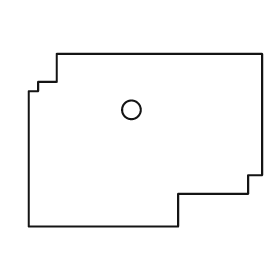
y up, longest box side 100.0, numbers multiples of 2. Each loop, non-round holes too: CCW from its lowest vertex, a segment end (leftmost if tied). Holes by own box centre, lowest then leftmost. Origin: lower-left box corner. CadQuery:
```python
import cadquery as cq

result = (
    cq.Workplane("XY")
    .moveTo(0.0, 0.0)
    .lineTo(64.0, 0.0)
    .lineTo(64.0, 14.0)
    .lineTo(94.0, 14.0)
    .lineTo(94.0, 22.0)
    .lineTo(100.0, 22.0)
    .lineTo(100.0, 74.0)
    .lineTo(12.0, 74.0)
    .lineTo(12.0, 62.0)
    .lineTo(4.0, 62.0)
    .lineTo(4.0, 58.0)
    .lineTo(0.0, 58.0)
    .close()
    .moveTo(44.0, 50.0)
    .circle(4.0)
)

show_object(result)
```